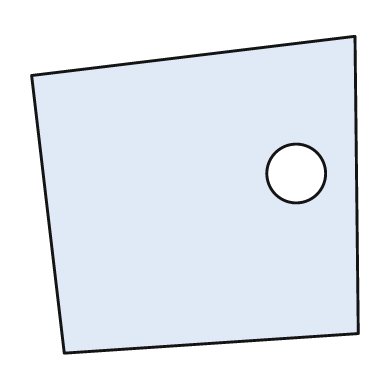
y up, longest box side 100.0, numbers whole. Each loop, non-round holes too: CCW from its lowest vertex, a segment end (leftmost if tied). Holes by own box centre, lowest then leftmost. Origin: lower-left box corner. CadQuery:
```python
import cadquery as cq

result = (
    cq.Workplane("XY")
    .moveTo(10.0, 0.0)
    .lineTo(100.0, 6.0)
    .lineTo(99.0, 97.0)
    .lineTo(0.0, 85.0)
    .close()
    .moveTo(81.0, 55.0)
    .circle(9.0)
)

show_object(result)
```